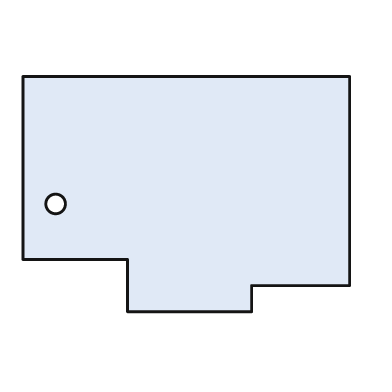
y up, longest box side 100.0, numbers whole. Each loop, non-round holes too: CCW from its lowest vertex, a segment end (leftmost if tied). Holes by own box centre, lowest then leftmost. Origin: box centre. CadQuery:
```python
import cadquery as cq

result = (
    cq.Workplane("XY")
    .moveTo(-18.0, -36.0)
    .lineTo(20.0, -36.0)
    .lineTo(20.0, -28.0)
    .lineTo(50.0, -28.0)
    .lineTo(50.0, 36.0)
    .lineTo(-50.0, 36.0)
    .lineTo(-50.0, -20.0)
    .lineTo(-18.0, -20.0)
    .close()
    .moveTo(-40.0, -3.0)
    .circle(3.0)
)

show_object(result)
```